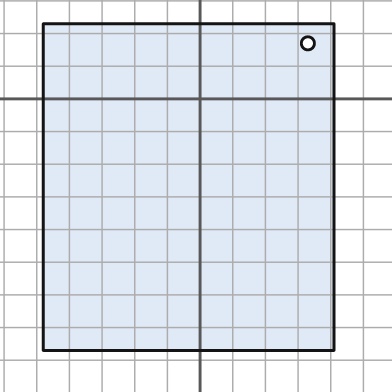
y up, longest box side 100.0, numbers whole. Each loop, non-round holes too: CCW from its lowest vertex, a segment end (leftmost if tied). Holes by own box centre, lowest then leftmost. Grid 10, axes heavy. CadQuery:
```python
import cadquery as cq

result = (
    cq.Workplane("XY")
    .moveTo(-48.0, -77.0)
    .lineTo(41.0, -77.0)
    .lineTo(41.0, 23.0)
    .lineTo(-48.0, 23.0)
    .close()
    .moveTo(33.0, 17.0)
    .circle(2.0)
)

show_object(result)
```